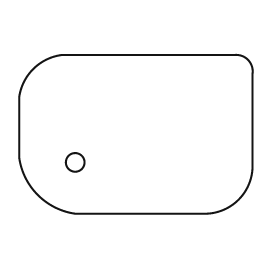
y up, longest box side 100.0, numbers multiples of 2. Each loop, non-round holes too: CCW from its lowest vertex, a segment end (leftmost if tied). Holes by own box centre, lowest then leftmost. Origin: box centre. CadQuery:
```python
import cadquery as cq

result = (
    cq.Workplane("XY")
    .moveTo(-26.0, -34.0)
    .lineTo(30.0, -34.0)
    .threePointArc((44.0, -28.0), (50.0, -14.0))
    .lineTo(50.0, 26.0)
    .threePointArc((48.0, 32.0), (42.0, 34.0))
    .lineTo(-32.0, 34.0)
    .threePointArc((-44.0, 28.0), (-50.0, 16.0))
    .lineTo(-50.0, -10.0)
    .threePointArc((-42.0, -26.0), (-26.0, -34.0))
    .close()
    .moveTo(-26.0, -12.0)
    .circle(4.0)
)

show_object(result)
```